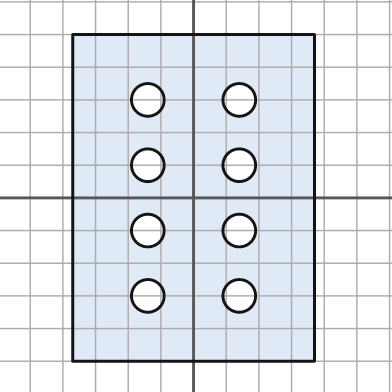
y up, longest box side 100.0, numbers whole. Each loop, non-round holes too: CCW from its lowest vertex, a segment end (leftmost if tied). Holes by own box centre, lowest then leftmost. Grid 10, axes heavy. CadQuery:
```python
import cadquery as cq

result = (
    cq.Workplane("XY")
    .moveTo(-37.0, -50.0)
    .lineTo(37.0, -50.0)
    .lineTo(37.0, 50.0)
    .lineTo(-37.0, 50.0)
    .close()
    .moveTo(-14.0, -30.0)
    .circle(5.0)
    .moveTo(14.0, -30.0)
    .circle(5.0)
    .moveTo(-14.0, -10.0)
    .circle(5.0)
    .moveTo(14.0, -10.0)
    .circle(5.0)
    .moveTo(-14.0, 10.0)
    .circle(5.0)
    .moveTo(14.0, 10.0)
    .circle(5.0)
    .moveTo(-14.0, 30.0)
    .circle(5.0)
    .moveTo(14.0, 30.0)
    .circle(5.0)
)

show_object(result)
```